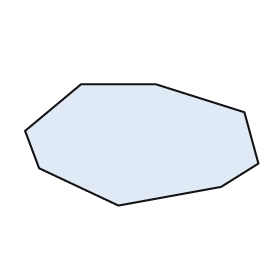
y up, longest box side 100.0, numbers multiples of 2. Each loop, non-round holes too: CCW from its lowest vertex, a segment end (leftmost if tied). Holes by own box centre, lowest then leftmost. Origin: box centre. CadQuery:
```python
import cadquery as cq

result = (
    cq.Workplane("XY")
    .moveTo(-10.0, -26.0)
    .lineTo(34.0, -18.0)
    .lineTo(50.0, -8.0)
    .lineTo(44.0, 14.0)
    .lineTo(6.0, 26.0)
    .lineTo(-26.0, 26.0)
    .lineTo(-50.0, 6.0)
    .lineTo(-44.0, -10.0)
    .close()
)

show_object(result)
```